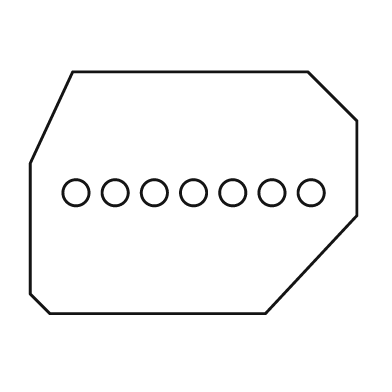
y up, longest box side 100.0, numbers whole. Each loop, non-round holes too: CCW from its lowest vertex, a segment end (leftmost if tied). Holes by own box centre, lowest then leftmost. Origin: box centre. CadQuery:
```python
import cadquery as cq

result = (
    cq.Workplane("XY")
    .moveTo(-44.0, -37.0)
    .lineTo(22.0, -37.0)
    .lineTo(50.0, -7.0)
    .lineTo(50.0, 22.0)
    .lineTo(35.0, 37.0)
    .lineTo(-37.0, 37.0)
    .lineTo(-50.0, 9.0)
    .lineTo(-50.0, -31.0)
    .close()
    .moveTo(-36.0, 0.0)
    .circle(4.0)
    .moveTo(-24.0, 0.0)
    .circle(4.0)
    .moveTo(-12.0, 0.0)
    .circle(4.0)
    .moveTo(0.0, 0.0)
    .circle(4.0)
    .moveTo(12.0, 0.0)
    .circle(4.0)
    .moveTo(24.0, 0.0)
    .circle(4.0)
    .moveTo(36.0, 0.0)
    .circle(4.0)
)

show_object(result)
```